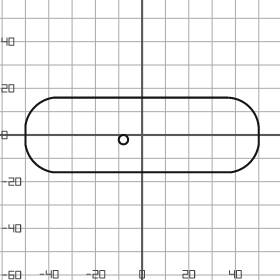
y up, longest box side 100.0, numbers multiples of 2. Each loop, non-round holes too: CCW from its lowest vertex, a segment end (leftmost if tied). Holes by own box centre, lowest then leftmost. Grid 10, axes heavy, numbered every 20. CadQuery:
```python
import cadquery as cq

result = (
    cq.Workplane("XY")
    .moveTo(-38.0, -16.0)
    .lineTo(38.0, -16.0)
    .threePointArc((46.0, -12.0), (50.0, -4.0))
    .lineTo(50.0, 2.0)
    .threePointArc((46.0, 12.0), (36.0, 16.0))
    .lineTo(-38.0, 16.0)
    .threePointArc((-46.0, 12.0), (-50.0, 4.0))
    .lineTo(-50.0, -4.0)
    .threePointArc((-46.0, -12.0), (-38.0, -16.0))
    .close()
    .moveTo(-8.0, -2.0)
    .circle(2.0)
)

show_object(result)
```